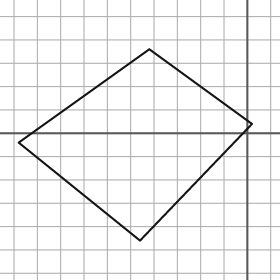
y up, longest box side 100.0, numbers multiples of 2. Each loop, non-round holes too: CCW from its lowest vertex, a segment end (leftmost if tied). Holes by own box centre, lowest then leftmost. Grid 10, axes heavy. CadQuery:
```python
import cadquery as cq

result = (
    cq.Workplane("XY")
    .moveTo(-46.0, -46.0)
    .lineTo(2.0, 4.0)
    .lineTo(-42.0, 36.0)
    .lineTo(-98.0, -4.0)
    .close()
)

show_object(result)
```